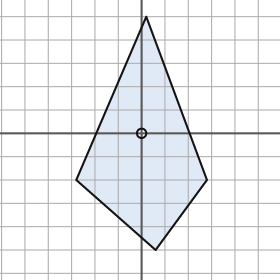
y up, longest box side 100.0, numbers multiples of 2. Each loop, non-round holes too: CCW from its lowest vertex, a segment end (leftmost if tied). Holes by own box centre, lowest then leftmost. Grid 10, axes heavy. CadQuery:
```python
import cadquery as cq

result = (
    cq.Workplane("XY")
    .moveTo(6.0, -50.0)
    .lineTo(28.0, -20.0)
    .lineTo(2.0, 50.0)
    .lineTo(-28.0, -20.0)
    .close()
    .moveTo(0.0, 0.0)
    .circle(2.0)
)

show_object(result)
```